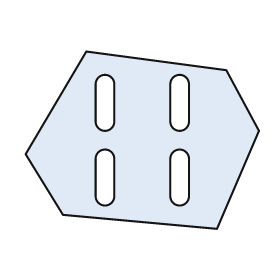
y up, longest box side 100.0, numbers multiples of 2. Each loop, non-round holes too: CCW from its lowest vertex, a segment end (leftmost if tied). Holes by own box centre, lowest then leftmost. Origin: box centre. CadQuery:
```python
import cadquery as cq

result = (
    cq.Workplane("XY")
    .moveTo(32.0, -38.0)
    .lineTo(50.0, 4.0)
    .lineTo(36.0, 30.0)
    .lineTo(-24.0, 38.0)
    .lineTo(-50.0, -6.0)
    .lineTo(-34.0, -32.0)
    .close()
    .moveTo(-20.0, -24.0)
    .threePointArc((-16.0, -28.0), (-12.0, -24.0))
    .lineTo(-12.0, -8.0)
    .threePointArc((-16.0, -4.0), (-20.0, -8.0))
    .close()
    .moveTo(12.0, -24.0)
    .threePointArc((16.0, -28.0), (20.0, -24.0))
    .lineTo(20.0, -8.0)
    .threePointArc((16.0, -4.0), (12.0, -8.0))
    .close()
    .moveTo(-20.0, 8.0)
    .threePointArc((-16.0, 4.0), (-12.0, 8.0))
    .lineTo(-12.0, 24.0)
    .threePointArc((-16.0, 28.0), (-20.0, 24.0))
    .close()
    .moveTo(12.0, 8.0)
    .threePointArc((16.0, 4.0), (20.0, 8.0))
    .lineTo(20.0, 24.0)
    .threePointArc((16.0, 28.0), (12.0, 24.0))
    .close()
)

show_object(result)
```